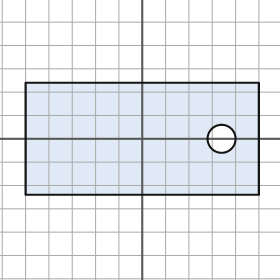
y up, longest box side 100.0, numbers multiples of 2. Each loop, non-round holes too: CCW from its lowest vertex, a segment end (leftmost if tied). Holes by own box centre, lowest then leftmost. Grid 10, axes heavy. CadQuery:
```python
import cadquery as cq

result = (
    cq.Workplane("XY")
    .moveTo(-50.0, -24.0)
    .lineTo(50.0, -24.0)
    .lineTo(50.0, 24.0)
    .lineTo(-50.0, 24.0)
    .close()
    .moveTo(34.0, 0.0)
    .circle(6.0)
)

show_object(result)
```